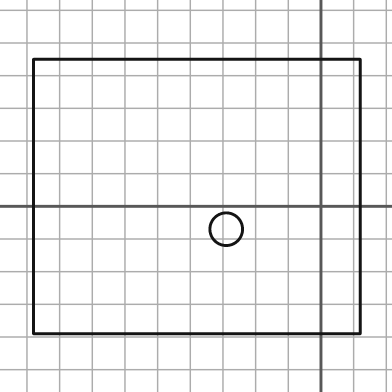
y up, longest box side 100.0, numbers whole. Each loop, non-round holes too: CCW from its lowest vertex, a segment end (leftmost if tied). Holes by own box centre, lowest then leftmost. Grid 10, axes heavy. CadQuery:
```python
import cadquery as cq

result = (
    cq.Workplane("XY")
    .moveTo(-88.0, -39.0)
    .lineTo(12.0, -39.0)
    .lineTo(12.0, 45.0)
    .lineTo(-88.0, 45.0)
    .close()
    .moveTo(-29.0, -7.0)
    .circle(5.0)
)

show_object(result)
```